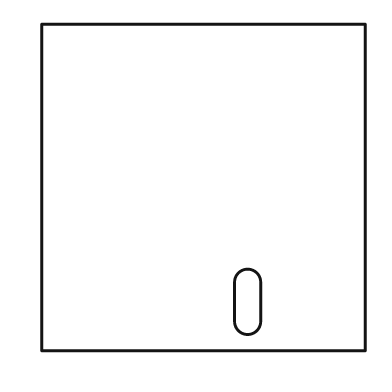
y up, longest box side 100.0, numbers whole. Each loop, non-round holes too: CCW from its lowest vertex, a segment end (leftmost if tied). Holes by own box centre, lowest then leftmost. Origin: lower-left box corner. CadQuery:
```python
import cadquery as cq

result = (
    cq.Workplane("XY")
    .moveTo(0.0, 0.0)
    .lineTo(99.0, 0.0)
    .lineTo(99.0, 100.0)
    .lineTo(0.0, 100.0)
    .close()
    .moveTo(59.0, 9.0)
    .threePointArc((63.0, 5.0), (67.0, 9.0))
    .lineTo(67.0, 21.0)
    .threePointArc((63.0, 25.0), (59.0, 21.0))
    .close()
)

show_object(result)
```